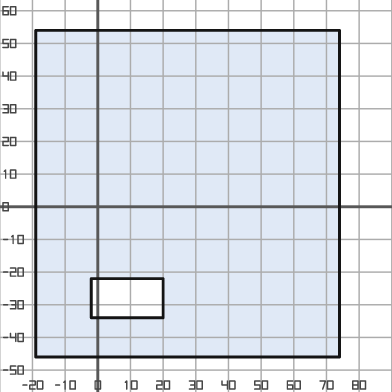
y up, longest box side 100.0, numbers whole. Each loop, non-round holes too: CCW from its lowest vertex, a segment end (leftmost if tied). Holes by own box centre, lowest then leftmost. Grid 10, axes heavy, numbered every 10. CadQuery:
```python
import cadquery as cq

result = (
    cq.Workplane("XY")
    .moveTo(-19.0, -46.0)
    .lineTo(74.0, -46.0)
    .lineTo(74.0, 54.0)
    .lineTo(-19.0, 54.0)
    .close()
    .moveTo(-2.0, -34.0)
    .lineTo(20.0, -34.0)
    .lineTo(20.0, -22.0)
    .lineTo(-2.0, -22.0)
    .close()
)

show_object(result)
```